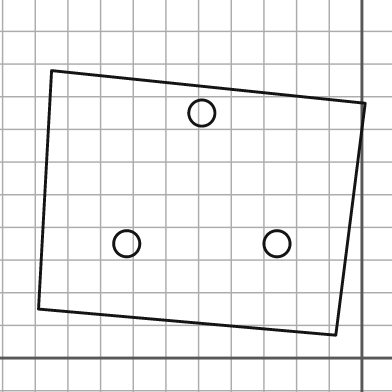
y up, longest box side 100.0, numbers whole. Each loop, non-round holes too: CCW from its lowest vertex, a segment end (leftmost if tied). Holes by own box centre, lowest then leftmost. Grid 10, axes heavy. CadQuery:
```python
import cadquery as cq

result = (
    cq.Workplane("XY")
    .moveTo(-8.0, 7.0)
    .lineTo(1.0, 78.0)
    .lineTo(-95.0, 88.0)
    .lineTo(-99.0, 15.0)
    .close()
    .moveTo(-72.0, 35.0)
    .circle(4.0)
    .moveTo(-26.0, 35.0)
    .circle(4.0)
    .moveTo(-49.0, 75.0)
    .circle(4.0)
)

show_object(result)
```